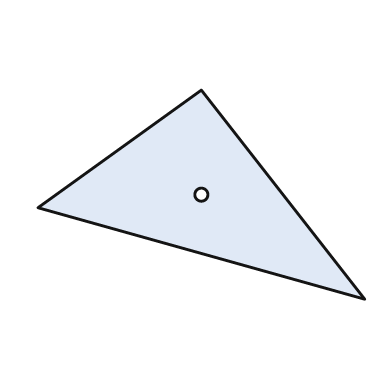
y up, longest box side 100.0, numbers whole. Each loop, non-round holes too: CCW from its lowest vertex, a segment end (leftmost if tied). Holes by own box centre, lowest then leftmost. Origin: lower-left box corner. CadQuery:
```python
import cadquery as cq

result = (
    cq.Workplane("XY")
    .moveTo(100.0, 0.0)
    .lineTo(50.0, 64.0)
    .lineTo(0.0, 28.0)
    .close()
    .moveTo(50.0, 32.0)
    .circle(2.0)
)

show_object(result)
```